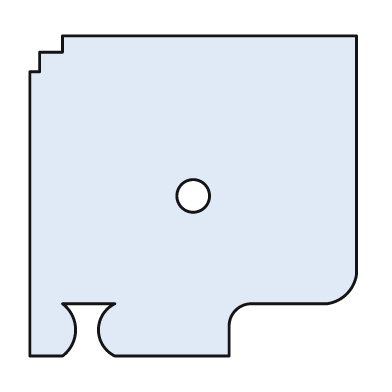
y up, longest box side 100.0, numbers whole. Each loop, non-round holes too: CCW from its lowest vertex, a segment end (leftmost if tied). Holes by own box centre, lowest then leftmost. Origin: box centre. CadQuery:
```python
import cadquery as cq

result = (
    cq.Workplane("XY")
    .moveTo(-50.0, -49.0)
    .lineTo(-40.0, -49.0)
    .threePointArc((-36.0, -41.0), (-40.0, -33.0))
    .lineTo(-24.0, -33.0)
    .threePointArc((-29.0, -41.0), (-24.0, -49.0))
    .lineTo(11.0, -49.0)
    .lineTo(11.0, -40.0)
    .threePointArc((13.0, -35.0), (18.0, -33.0))
    .lineTo(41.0, -33.0)
    .threePointArc((47.0, -30.0), (50.0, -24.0))
    .lineTo(50.0, 49.0)
    .lineTo(-40.0, 49.0)
    .lineTo(-40.0, 44.0)
    .lineTo(-47.0, 44.0)
    .lineTo(-47.0, 38.0)
    .lineTo(-50.0, 38.0)
    .close()
    .moveTo(0.0, 0.0)
    .circle(5.0)
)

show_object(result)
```